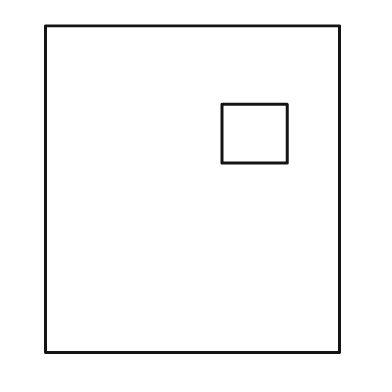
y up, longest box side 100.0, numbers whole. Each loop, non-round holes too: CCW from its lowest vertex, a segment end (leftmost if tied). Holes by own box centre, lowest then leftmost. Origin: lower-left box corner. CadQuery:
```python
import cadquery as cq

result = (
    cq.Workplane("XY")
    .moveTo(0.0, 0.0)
    .lineTo(90.0, 0.0)
    .lineTo(90.0, 100.0)
    .lineTo(0.0, 100.0)
    .close()
    .moveTo(54.0, 58.0)
    .lineTo(74.0, 58.0)
    .lineTo(74.0, 76.0)
    .lineTo(54.0, 76.0)
    .close()
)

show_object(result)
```